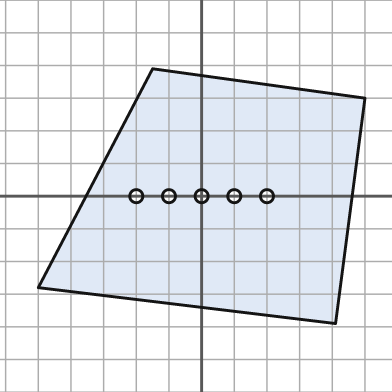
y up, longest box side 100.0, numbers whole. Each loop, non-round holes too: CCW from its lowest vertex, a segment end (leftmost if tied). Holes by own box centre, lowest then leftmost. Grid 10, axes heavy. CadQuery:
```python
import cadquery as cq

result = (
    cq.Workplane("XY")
    .moveTo(41.0, -39.0)
    .lineTo(50.0, 30.0)
    .lineTo(-15.0, 39.0)
    .lineTo(-50.0, -28.0)
    .close()
    .moveTo(-20.0, 0.0)
    .circle(2.0)
    .moveTo(-10.0, 0.0)
    .circle(2.0)
    .moveTo(0.0, 0.0)
    .circle(2.0)
    .moveTo(10.0, 0.0)
    .circle(2.0)
    .moveTo(20.0, 0.0)
    .circle(2.0)
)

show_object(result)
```